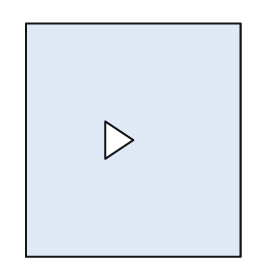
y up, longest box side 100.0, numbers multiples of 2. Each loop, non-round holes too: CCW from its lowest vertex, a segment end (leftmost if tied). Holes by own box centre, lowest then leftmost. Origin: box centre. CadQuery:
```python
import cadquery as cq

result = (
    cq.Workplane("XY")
    .moveTo(-46.0, -50.0)
    .lineTo(46.0, -50.0)
    .lineTo(46.0, 50.0)
    .lineTo(-46.0, 50.0)
    .close()
    .moveTo(-12.0, -8.0)
    .lineTo(0.0, 0.0)
    .lineTo(-12.0, 8.0)
    .close()
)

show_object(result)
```